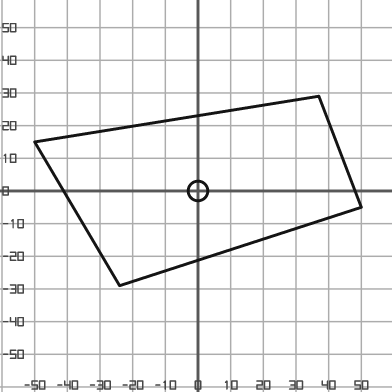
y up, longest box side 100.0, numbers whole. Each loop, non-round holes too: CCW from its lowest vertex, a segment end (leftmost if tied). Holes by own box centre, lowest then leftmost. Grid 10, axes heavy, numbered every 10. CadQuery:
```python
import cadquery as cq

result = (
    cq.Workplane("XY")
    .moveTo(-24.0, -29.0)
    .lineTo(50.0, -5.0)
    .lineTo(37.0, 29.0)
    .lineTo(-50.0, 15.0)
    .close()
    .moveTo(0.0, 0.0)
    .circle(3.0)
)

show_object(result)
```